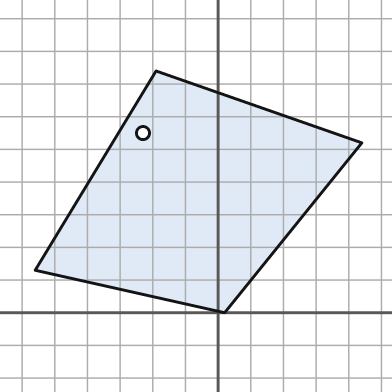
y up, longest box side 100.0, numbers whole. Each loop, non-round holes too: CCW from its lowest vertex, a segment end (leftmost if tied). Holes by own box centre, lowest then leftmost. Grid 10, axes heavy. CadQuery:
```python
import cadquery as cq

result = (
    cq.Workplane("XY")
    .moveTo(2.0, 0.0)
    .lineTo(44.0, 52.0)
    .lineTo(-19.0, 74.0)
    .lineTo(-56.0, 13.0)
    .close()
    .moveTo(-23.0, 55.0)
    .circle(2.0)
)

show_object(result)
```